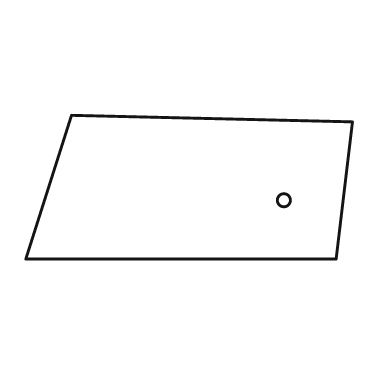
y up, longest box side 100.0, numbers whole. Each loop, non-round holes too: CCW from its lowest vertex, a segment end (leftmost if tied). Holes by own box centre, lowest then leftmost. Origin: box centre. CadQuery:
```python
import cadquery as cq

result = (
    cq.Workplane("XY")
    .moveTo(-50.0, -22.0)
    .lineTo(45.0, -22.0)
    .lineTo(50.0, 20.0)
    .lineTo(-36.0, 22.0)
    .close()
    .moveTo(29.0, -4.0)
    .circle(2.0)
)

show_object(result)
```